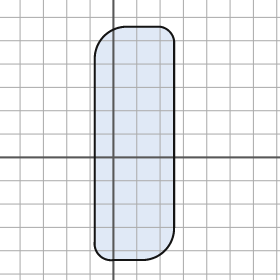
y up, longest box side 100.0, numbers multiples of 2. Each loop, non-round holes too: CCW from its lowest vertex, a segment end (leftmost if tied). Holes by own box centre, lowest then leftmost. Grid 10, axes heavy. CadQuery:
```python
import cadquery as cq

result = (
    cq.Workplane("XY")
    .moveTo(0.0, -44.0)
    .lineTo(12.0, -44.0)
    .threePointArc((22.0, -40.0), (26.0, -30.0))
    .lineTo(26.0, 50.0)
    .threePointArc((24.0, 54.0), (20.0, 56.0))
    .lineTo(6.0, 56.0)
    .threePointArc((-4.0, 52.0), (-8.0, 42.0))
    .lineTo(-8.0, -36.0)
    .threePointArc((-6.0, -42.0), (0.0, -44.0))
    .close()
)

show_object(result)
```